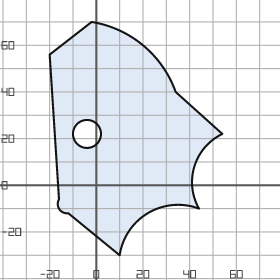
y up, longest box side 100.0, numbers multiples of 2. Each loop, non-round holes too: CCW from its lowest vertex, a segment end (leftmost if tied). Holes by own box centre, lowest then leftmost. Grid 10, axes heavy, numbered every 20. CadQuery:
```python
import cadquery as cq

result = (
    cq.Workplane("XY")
    .moveTo(10.0, -30.0)
    .threePointArc((22.0, -12.0), (44.0, -10.0))
    .threePointArc((42.0, 8.0), (54.0, 22.0))
    .lineTo(34.0, 40.0)
    .threePointArc((20.0, 60.0), (-2.0, 70.0))
    .lineTo(-20.0, 56.0)
    .lineTo(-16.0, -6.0)
    .threePointArc((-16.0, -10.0), (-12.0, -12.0))
    .close()
    .moveTo(-4.0, 22.0)
    .circle(6.0)
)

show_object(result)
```